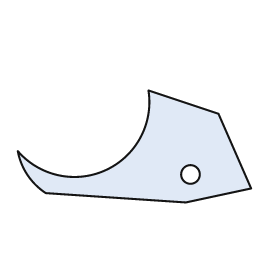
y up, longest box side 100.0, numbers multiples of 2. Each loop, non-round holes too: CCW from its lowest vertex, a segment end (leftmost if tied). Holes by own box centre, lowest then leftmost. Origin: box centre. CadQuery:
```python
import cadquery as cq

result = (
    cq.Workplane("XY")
    .moveTo(22.0, -24.0)
    .lineTo(50.0, -18.0)
    .lineTo(36.0, 14.0)
    .lineTo(6.0, 24.0)
    .threePointArc((-12.0, -10.0), (-50.0, -2.0))
    .threePointArc((-46.0, -12.0), (-38.0, -20.0))
    .close()
    .moveTo(24.0, -12.0)
    .circle(4.0)
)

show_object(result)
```